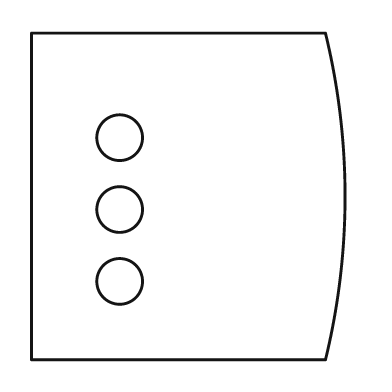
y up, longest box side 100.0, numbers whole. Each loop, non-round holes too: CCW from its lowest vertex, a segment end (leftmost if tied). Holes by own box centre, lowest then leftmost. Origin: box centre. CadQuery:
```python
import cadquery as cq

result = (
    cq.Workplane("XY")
    .moveTo(-48.0, -50.0)
    .lineTo(42.0, -50.0)
    .threePointArc((48.0, 0.0), (42.0, 50.0))
    .lineTo(-48.0, 50.0)
    .close()
    .moveTo(-21.0, -26.0)
    .circle(7.0)
    .moveTo(-21.0, -4.0)
    .circle(7.0)
    .moveTo(-21.0, 18.0)
    .circle(7.0)
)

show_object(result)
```